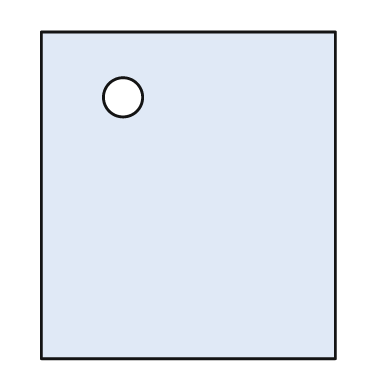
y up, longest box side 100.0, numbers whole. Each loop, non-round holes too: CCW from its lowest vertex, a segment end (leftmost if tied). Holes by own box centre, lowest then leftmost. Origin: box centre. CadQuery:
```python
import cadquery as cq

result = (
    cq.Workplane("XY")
    .moveTo(-45.0, -50.0)
    .lineTo(45.0, -50.0)
    .lineTo(45.0, 50.0)
    .lineTo(-45.0, 50.0)
    .close()
    .moveTo(-20.0, 30.0)
    .circle(6.0)
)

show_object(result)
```